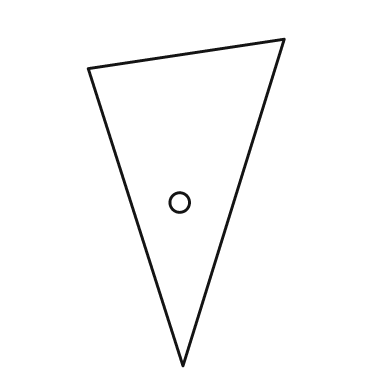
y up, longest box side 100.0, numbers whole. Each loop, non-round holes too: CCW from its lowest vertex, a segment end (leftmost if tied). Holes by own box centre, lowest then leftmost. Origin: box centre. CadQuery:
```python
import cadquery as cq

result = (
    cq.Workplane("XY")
    .moveTo(-1.0, -50.0)
    .lineTo(30.0, 50.0)
    .lineTo(-30.0, 41.0)
    .close()
    .moveTo(-2.0, 0.0)
    .circle(3.0)
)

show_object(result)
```